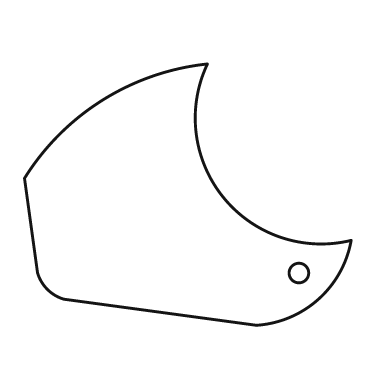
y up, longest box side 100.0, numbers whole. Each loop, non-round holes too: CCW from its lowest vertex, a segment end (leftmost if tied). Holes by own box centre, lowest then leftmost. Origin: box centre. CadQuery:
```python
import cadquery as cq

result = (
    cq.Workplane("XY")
    .moveTo(21.0, -40.0)
    .threePointArc((40.0, -32.0), (50.0, -14.0))
    .threePointArc((11.0, -1.0), (6.0, 40.0))
    .threePointArc((-26.0, 29.0), (-50.0, 5.0))
    .lineTo(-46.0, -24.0)
    .threePointArc((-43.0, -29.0), (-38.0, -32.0))
    .close()
    .moveTo(34.0, -24.0)
    .circle(3.0)
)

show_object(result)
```